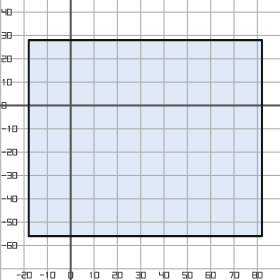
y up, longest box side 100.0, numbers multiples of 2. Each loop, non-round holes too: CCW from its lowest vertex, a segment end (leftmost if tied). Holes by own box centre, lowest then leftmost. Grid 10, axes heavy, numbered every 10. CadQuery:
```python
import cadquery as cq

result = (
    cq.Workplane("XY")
    .moveTo(-18.0, -56.0)
    .lineTo(82.0, -56.0)
    .lineTo(82.0, 28.0)
    .lineTo(-18.0, 28.0)
    .close()
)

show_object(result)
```